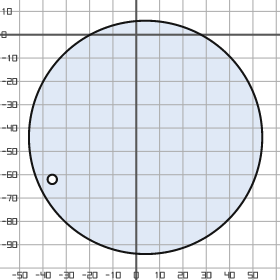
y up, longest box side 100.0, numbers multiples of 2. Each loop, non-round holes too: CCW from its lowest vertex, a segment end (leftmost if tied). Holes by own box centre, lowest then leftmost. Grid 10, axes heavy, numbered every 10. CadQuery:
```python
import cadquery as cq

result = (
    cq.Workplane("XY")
    .moveTo(4.0, -44.0)
    .circle(50.0)
    .moveTo(-36.0, -62.0)
    .circle(2.0)
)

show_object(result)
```